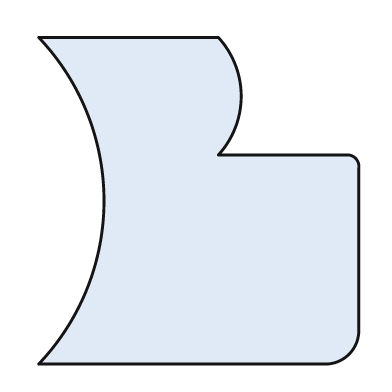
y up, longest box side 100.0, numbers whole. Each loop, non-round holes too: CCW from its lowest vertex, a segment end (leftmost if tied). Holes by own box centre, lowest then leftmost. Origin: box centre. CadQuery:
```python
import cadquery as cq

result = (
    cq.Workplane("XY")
    .moveTo(-49.0, -50.0)
    .lineTo(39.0, -50.0)
    .threePointArc((46.0, -47.0), (49.0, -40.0))
    .lineTo(49.0, 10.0)
    .threePointArc((48.0, 13.0), (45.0, 14.0))
    .lineTo(6.0, 14.0)
    .threePointArc((13.0, 32.0), (6.0, 50.0))
    .lineTo(-49.0, 50.0)
    .threePointArc((-29.0, 0.0), (-49.0, -50.0))
    .close()
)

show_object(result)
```